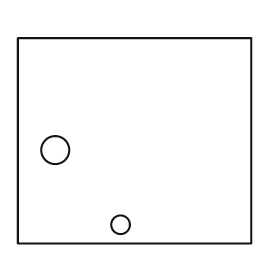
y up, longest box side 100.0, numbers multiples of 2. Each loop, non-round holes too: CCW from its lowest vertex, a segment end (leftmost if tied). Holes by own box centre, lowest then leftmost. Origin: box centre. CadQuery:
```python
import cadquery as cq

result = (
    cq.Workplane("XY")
    .moveTo(-50.0, -44.0)
    .lineTo(50.0, -44.0)
    .lineTo(50.0, 44.0)
    .lineTo(-50.0, 44.0)
    .close()
    .moveTo(-6.0, -36.0)
    .circle(4.0)
    .moveTo(-34.0, -4.0)
    .circle(6.0)
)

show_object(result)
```